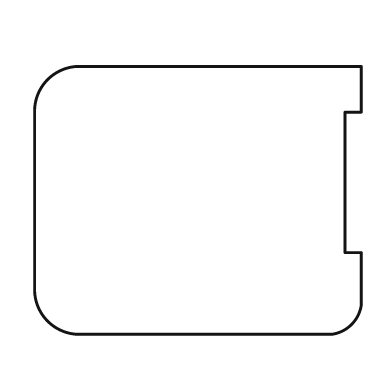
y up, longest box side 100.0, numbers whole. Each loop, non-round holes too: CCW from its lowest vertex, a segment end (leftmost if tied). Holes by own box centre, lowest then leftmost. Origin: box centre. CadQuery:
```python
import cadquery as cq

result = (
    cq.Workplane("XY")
    .moveTo(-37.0, -41.0)
    .lineTo(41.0, -41.0)
    .threePointArc((47.0, -38.0), (50.0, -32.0))
    .lineTo(50.0, -16.0)
    .lineTo(45.0, -16.0)
    .lineTo(45.0, 27.0)
    .lineTo(50.0, 27.0)
    .lineTo(50.0, 41.0)
    .lineTo(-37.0, 41.0)
    .threePointArc((-46.0, 37.0), (-50.0, 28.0))
    .lineTo(-50.0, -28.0)
    .threePointArc((-46.0, -37.0), (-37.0, -41.0))
    .close()
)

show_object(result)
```